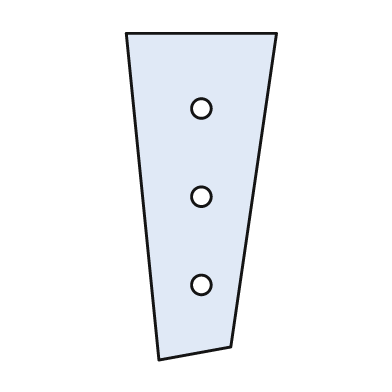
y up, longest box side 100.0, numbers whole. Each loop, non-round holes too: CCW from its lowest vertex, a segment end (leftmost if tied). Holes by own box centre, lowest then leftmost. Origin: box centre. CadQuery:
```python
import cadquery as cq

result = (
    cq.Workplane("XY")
    .moveTo(-13.0, -50.0)
    .lineTo(9.0, -46.0)
    .lineTo(23.0, 50.0)
    .lineTo(-23.0, 50.0)
    .close()
    .moveTo(0.0, -27.0)
    .circle(3.0)
    .moveTo(0.0, 0.0)
    .circle(3.0)
    .moveTo(0.0, 27.0)
    .circle(3.0)
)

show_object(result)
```